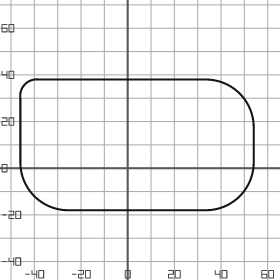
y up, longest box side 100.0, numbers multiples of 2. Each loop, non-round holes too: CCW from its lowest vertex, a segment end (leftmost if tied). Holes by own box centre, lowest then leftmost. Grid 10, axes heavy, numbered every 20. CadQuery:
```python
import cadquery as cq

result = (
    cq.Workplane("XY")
    .moveTo(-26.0, -18.0)
    .lineTo(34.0, -18.0)
    .threePointArc((48.0, -12.0), (54.0, 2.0))
    .lineTo(54.0, 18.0)
    .threePointArc((48.0, 32.0), (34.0, 38.0))
    .lineTo(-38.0, 38.0)
    .threePointArc((-44.0, 36.0), (-46.0, 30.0))
    .lineTo(-46.0, 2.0)
    .threePointArc((-40.0, -12.0), (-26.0, -18.0))
    .close()
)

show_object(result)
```